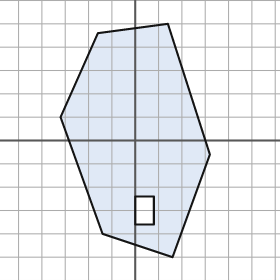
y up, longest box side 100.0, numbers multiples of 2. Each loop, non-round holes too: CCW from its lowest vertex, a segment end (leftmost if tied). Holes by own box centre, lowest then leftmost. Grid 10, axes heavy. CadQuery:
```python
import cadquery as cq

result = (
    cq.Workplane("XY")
    .moveTo(16.0, -50.0)
    .lineTo(32.0, -6.0)
    .lineTo(14.0, 50.0)
    .lineTo(-16.0, 46.0)
    .lineTo(-32.0, 10.0)
    .lineTo(-14.0, -40.0)
    .close()
    .moveTo(0.0, -36.0)
    .lineTo(8.0, -36.0)
    .lineTo(8.0, -24.0)
    .lineTo(0.0, -24.0)
    .close()
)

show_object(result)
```